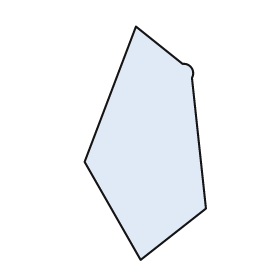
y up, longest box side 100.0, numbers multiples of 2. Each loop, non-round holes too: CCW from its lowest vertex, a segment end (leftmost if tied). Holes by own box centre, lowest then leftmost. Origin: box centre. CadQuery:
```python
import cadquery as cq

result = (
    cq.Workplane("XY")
    .moveTo(-2.0, -50.0)
    .lineTo(26.0, -28.0)
    .lineTo(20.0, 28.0)
    .threePointArc((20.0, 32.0), (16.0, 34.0))
    .lineTo(-4.0, 50.0)
    .lineTo(-26.0, -8.0)
    .close()
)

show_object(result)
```